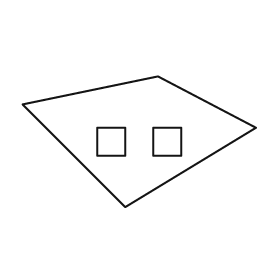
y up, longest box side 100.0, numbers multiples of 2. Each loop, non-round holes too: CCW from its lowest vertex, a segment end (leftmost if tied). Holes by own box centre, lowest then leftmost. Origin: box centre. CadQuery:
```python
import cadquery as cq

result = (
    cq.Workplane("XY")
    .moveTo(-6.0, -28.0)
    .lineTo(50.0, 6.0)
    .lineTo(8.0, 28.0)
    .lineTo(-50.0, 16.0)
    .close()
    .moveTo(-18.0, -6.0)
    .lineTo(-6.0, -6.0)
    .lineTo(-6.0, 6.0)
    .lineTo(-18.0, 6.0)
    .close()
    .moveTo(6.0, -6.0)
    .lineTo(18.0, -6.0)
    .lineTo(18.0, 6.0)
    .lineTo(6.0, 6.0)
    .close()
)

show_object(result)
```